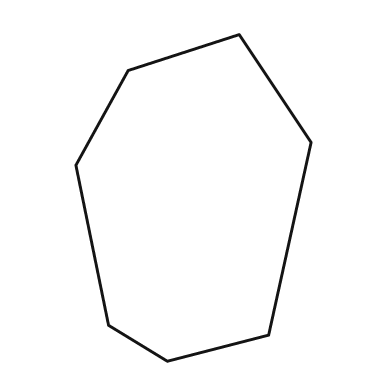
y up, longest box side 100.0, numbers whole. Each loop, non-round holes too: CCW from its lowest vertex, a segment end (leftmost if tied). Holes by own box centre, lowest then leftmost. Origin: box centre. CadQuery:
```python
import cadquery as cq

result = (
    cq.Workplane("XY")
    .moveTo(-8.0, -50.0)
    .lineTo(23.0, -42.0)
    .lineTo(36.0, 17.0)
    .lineTo(14.0, 50.0)
    .lineTo(-20.0, 39.0)
    .lineTo(-36.0, 10.0)
    .lineTo(-26.0, -39.0)
    .close()
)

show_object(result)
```